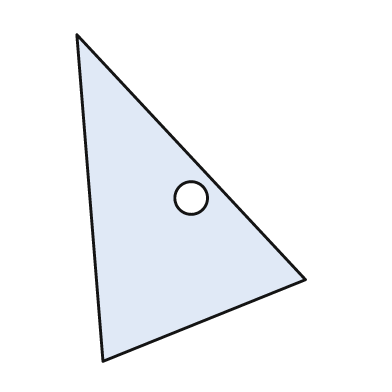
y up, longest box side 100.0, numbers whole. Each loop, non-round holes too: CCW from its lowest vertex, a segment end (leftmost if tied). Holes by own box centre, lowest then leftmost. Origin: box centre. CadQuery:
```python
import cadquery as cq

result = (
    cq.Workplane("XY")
    .moveTo(-27.0, -50.0)
    .lineTo(35.0, -25.0)
    .lineTo(-35.0, 50.0)
    .close()
    .moveTo(0.0, 0.0)
    .circle(5.0)
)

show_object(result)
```